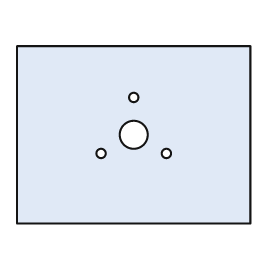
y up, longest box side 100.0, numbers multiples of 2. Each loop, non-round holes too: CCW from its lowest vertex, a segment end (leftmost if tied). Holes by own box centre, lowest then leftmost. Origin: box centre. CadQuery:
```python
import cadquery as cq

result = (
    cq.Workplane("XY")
    .moveTo(-50.0, -38.0)
    .lineTo(50.0, -38.0)
    .lineTo(50.0, 38.0)
    .lineTo(-50.0, 38.0)
    .close()
    .moveTo(-14.0, -8.0)
    .circle(2.0)
    .moveTo(14.0, -8.0)
    .circle(2.0)
    .moveTo(0.0, 0.0)
    .circle(6.0)
    .moveTo(0.0, 16.0)
    .circle(2.0)
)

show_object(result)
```